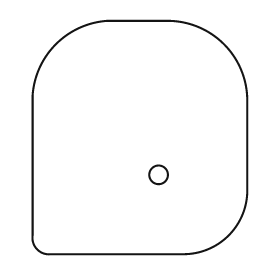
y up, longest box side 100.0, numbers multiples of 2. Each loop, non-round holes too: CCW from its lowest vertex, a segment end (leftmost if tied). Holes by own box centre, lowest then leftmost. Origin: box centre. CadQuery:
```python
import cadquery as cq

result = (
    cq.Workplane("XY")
    .moveTo(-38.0, -50.0)
    .lineTo(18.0, -50.0)
    .threePointArc((38.0, -42.0), (46.0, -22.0))
    .lineTo(46.0, 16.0)
    .threePointArc((36.0, 40.0), (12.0, 50.0))
    .lineTo(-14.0, 50.0)
    .threePointArc((-36.0, 40.0), (-46.0, 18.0))
    .lineTo(-46.0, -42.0)
    .threePointArc((-44.0, -48.0), (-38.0, -50.0))
    .close()
    .moveTo(8.0, -16.0)
    .circle(4.0)
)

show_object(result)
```